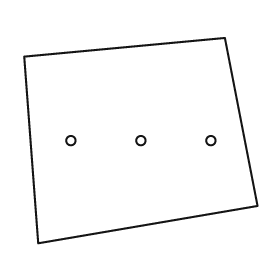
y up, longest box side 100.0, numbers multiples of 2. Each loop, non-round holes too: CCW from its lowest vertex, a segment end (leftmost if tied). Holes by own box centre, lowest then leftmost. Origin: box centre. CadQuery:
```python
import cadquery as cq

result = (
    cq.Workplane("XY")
    .moveTo(-44.0, -44.0)
    .lineTo(50.0, -28.0)
    .lineTo(36.0, 44.0)
    .lineTo(-50.0, 36.0)
    .close()
    .moveTo(-30.0, 0.0)
    .circle(2.0)
    .moveTo(0.0, 0.0)
    .circle(2.0)
    .moveTo(30.0, 0.0)
    .circle(2.0)
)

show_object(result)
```